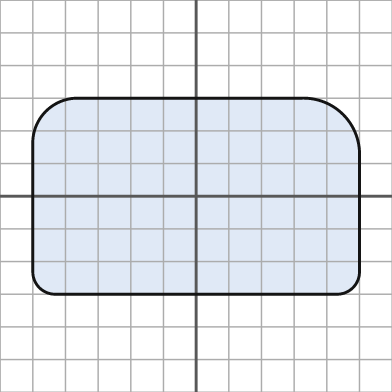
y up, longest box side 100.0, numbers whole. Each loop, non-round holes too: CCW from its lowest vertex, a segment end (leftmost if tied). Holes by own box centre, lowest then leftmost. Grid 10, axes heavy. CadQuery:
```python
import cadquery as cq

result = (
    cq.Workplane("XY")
    .moveTo(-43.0, -30.0)
    .lineTo(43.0, -30.0)
    .threePointArc((48.0, -28.0), (50.0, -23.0))
    .lineTo(50.0, 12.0)
    .threePointArc((45.0, 25.0), (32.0, 30.0))
    .lineTo(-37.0, 30.0)
    .threePointArc((-46.0, 26.0), (-50.0, 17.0))
    .lineTo(-50.0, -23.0)
    .threePointArc((-48.0, -28.0), (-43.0, -30.0))
    .close()
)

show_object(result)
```